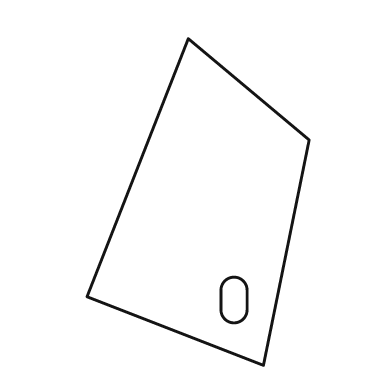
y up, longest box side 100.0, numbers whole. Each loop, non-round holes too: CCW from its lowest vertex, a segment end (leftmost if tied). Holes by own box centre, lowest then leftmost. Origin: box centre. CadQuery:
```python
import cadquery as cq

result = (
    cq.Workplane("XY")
    .moveTo(20.0, -50.0)
    .lineTo(34.0, 19.0)
    .lineTo(-3.0, 50.0)
    .lineTo(-34.0, -29.0)
    .close()
    .moveTo(7.0, -33.0)
    .threePointArc((11.0, -37.0), (15.0, -33.0))
    .lineTo(15.0, -27.0)
    .threePointArc((11.0, -23.0), (7.0, -27.0))
    .close()
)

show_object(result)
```